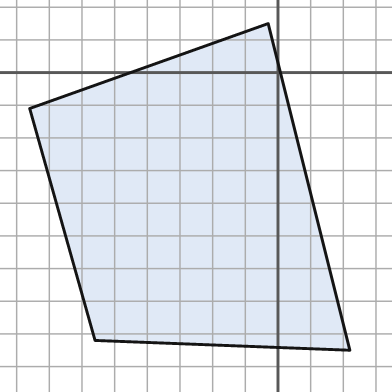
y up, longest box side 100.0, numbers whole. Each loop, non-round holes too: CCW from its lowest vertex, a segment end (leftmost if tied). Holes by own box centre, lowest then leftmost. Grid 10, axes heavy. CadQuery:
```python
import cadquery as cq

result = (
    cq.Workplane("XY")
    .moveTo(22.0, -85.0)
    .lineTo(-3.0, 15.0)
    .lineTo(-76.0, -11.0)
    .lineTo(-56.0, -82.0)
    .close()
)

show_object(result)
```